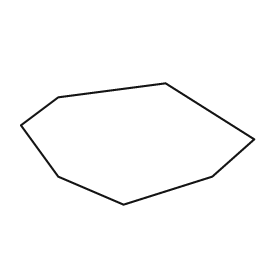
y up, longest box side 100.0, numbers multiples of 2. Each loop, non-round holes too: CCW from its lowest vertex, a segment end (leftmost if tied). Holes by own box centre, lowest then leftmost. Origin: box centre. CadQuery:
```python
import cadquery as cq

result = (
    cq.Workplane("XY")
    .moveTo(-6.0, -26.0)
    .lineTo(32.0, -14.0)
    .lineTo(50.0, 2.0)
    .lineTo(12.0, 26.0)
    .lineTo(-34.0, 20.0)
    .lineTo(-50.0, 8.0)
    .lineTo(-34.0, -14.0)
    .close()
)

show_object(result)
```